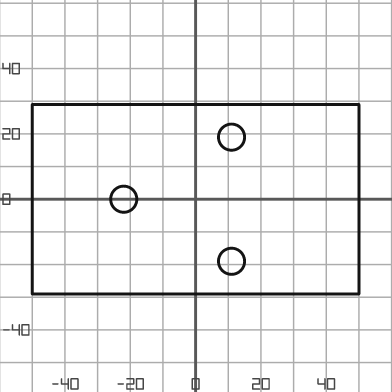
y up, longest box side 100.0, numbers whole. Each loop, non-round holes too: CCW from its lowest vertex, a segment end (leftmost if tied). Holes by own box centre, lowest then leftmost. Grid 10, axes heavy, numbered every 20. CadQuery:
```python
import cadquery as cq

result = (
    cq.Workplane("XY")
    .moveTo(-50.0, -29.0)
    .lineTo(50.0, -29.0)
    .lineTo(50.0, 29.0)
    .lineTo(-50.0, 29.0)
    .close()
    .moveTo(11.0, -19.0)
    .circle(4.0)
    .moveTo(-22.0, 0.0)
    .circle(4.0)
    .moveTo(11.0, 19.0)
    .circle(4.0)
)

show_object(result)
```